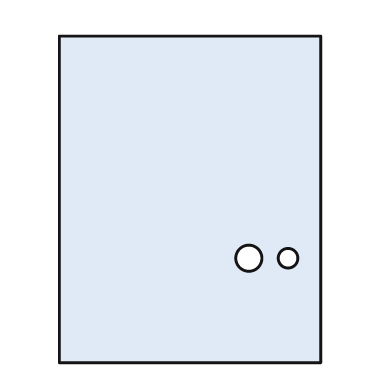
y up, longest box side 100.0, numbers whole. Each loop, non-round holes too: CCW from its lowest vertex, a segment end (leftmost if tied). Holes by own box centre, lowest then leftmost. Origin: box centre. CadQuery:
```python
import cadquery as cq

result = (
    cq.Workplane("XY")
    .moveTo(-40.0, -50.0)
    .lineTo(40.0, -50.0)
    .lineTo(40.0, 50.0)
    .lineTo(-40.0, 50.0)
    .close()
    .moveTo(18.0, -18.0)
    .circle(4.0)
    .moveTo(30.0, -18.0)
    .circle(3.0)
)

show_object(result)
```